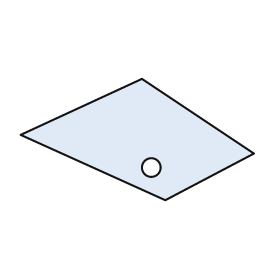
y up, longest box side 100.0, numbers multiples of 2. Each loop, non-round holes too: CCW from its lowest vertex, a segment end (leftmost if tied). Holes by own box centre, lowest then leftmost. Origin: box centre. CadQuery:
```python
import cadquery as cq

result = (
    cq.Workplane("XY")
    .moveTo(12.0, -26.0)
    .lineTo(50.0, -6.0)
    .lineTo(2.0, 26.0)
    .lineTo(-50.0, 2.0)
    .close()
    .moveTo(6.0, -12.0)
    .circle(4.0)
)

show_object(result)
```